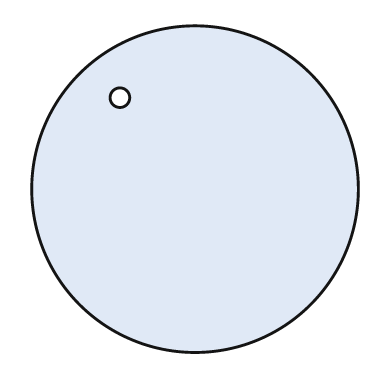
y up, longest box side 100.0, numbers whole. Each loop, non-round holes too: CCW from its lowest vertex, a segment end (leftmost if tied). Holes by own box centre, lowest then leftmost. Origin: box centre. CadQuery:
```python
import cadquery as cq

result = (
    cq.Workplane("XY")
    .moveTo(0.0, 0.0)
    .circle(50.0)
    .moveTo(-23.0, 28.0)
    .circle(3.0)
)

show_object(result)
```